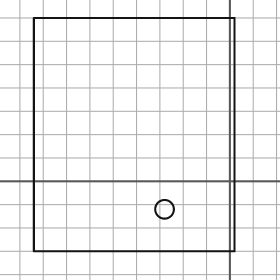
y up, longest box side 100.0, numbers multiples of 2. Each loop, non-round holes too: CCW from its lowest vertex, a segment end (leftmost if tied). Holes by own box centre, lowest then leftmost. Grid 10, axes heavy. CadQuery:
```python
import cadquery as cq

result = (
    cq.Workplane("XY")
    .moveTo(-84.0, -30.0)
    .lineTo(2.0, -30.0)
    .lineTo(2.0, 70.0)
    .lineTo(-84.0, 70.0)
    .close()
    .moveTo(-28.0, -12.0)
    .circle(4.0)
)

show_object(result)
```